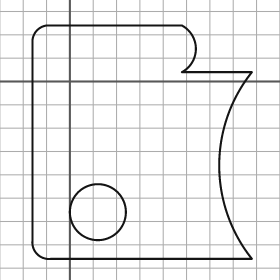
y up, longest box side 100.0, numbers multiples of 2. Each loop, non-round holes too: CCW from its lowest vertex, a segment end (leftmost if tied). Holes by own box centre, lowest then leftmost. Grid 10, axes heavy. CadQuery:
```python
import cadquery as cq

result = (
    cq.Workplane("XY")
    .moveTo(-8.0, -76.0)
    .lineTo(78.0, -76.0)
    .threePointArc((64.0, -36.0), (78.0, 4.0))
    .lineTo(48.0, 4.0)
    .threePointArc((54.0, 14.0), (48.0, 24.0))
    .lineTo(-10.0, 24.0)
    .threePointArc((-14.0, 22.0), (-16.0, 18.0))
    .lineTo(-16.0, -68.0)
    .threePointArc((-14.0, -74.0), (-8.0, -76.0))
    .close()
    .moveTo(12.0, -56.0)
    .circle(12.0)
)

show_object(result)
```